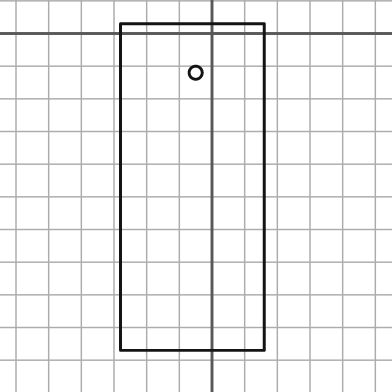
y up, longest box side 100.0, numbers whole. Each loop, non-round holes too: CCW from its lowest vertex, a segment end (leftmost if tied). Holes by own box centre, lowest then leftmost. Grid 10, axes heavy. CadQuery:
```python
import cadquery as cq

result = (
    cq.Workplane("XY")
    .moveTo(-28.0, -97.0)
    .lineTo(16.0, -97.0)
    .lineTo(16.0, 3.0)
    .lineTo(-28.0, 3.0)
    .close()
    .moveTo(-5.0, -12.0)
    .circle(2.0)
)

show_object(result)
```